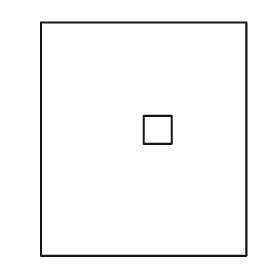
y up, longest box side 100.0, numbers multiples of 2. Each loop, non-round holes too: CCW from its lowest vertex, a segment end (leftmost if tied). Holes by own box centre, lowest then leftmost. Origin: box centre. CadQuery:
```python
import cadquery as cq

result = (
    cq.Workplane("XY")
    .moveTo(-44.0, -50.0)
    .lineTo(44.0, -50.0)
    .lineTo(44.0, 50.0)
    .lineTo(-44.0, 50.0)
    .close()
    .moveTo(0.0, -2.0)
    .lineTo(12.0, -2.0)
    .lineTo(12.0, 10.0)
    .lineTo(0.0, 10.0)
    .close()
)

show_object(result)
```